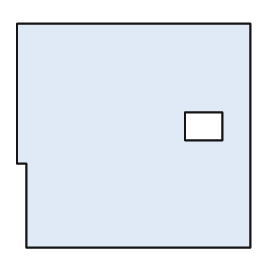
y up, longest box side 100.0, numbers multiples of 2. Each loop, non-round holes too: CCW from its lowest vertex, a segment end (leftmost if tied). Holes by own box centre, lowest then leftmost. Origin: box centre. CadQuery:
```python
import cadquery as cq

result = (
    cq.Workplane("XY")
    .moveTo(-46.0, -48.0)
    .lineTo(50.0, -48.0)
    .lineTo(50.0, 48.0)
    .lineTo(-50.0, 48.0)
    .lineTo(-50.0, -12.0)
    .lineTo(-46.0, -12.0)
    .close()
    .moveTo(22.0, -2.0)
    .lineTo(38.0, -2.0)
    .lineTo(38.0, 10.0)
    .lineTo(22.0, 10.0)
    .close()
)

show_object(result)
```